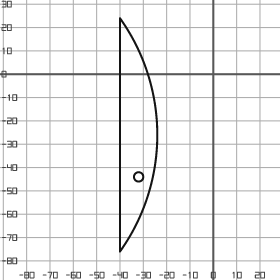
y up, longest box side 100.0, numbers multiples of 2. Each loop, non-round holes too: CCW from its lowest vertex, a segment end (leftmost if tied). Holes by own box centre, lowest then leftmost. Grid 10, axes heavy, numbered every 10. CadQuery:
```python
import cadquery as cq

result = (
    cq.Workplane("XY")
    .moveTo(-40.0, -76.0)
    .threePointArc((-24.0, -26.0), (-40.0, 24.0))
    .close()
    .moveTo(-32.0, -44.0)
    .circle(2.0)
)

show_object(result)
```